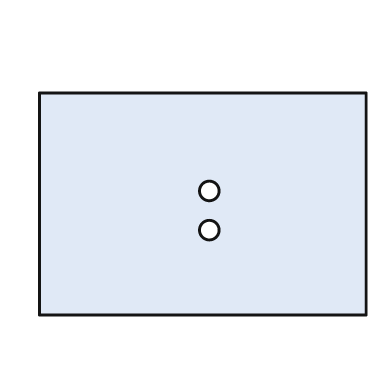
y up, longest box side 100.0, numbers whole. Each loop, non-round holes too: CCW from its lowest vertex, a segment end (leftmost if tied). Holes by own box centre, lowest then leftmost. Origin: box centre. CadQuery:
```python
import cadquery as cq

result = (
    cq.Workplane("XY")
    .moveTo(-50.0, -34.0)
    .lineTo(50.0, -34.0)
    .lineTo(50.0, 34.0)
    .lineTo(-50.0, 34.0)
    .close()
    .moveTo(2.0, -8.0)
    .circle(3.0)
    .moveTo(2.0, 4.0)
    .circle(3.0)
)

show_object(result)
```